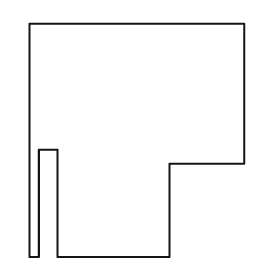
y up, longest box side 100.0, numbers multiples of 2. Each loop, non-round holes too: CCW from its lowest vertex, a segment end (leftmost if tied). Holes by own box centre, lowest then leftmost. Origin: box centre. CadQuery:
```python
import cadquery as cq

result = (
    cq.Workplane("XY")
    .moveTo(-46.0, -50.0)
    .lineTo(-42.0, -50.0)
    .lineTo(-42.0, -4.0)
    .lineTo(-34.0, -4.0)
    .lineTo(-34.0, -50.0)
    .lineTo(14.0, -50.0)
    .lineTo(14.0, -10.0)
    .lineTo(46.0, -10.0)
    .lineTo(46.0, 50.0)
    .lineTo(-46.0, 50.0)
    .close()
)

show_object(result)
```